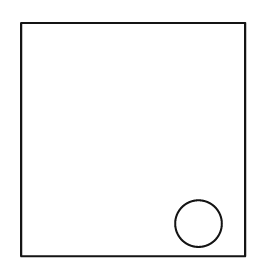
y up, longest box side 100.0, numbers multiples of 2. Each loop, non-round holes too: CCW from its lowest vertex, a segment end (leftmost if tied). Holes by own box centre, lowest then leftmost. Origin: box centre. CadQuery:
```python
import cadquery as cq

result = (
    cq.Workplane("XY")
    .moveTo(-48.0, -50.0)
    .lineTo(48.0, -50.0)
    .lineTo(48.0, 50.0)
    .lineTo(-48.0, 50.0)
    .close()
    .moveTo(28.0, -36.0)
    .circle(10.0)
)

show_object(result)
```